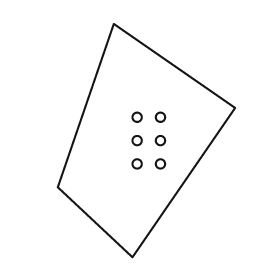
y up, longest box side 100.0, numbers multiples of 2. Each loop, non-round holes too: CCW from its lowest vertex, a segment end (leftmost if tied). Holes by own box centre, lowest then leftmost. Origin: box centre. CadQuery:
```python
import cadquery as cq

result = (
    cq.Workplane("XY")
    .moveTo(-6.0, -50.0)
    .lineTo(38.0, 14.0)
    .lineTo(-14.0, 50.0)
    .lineTo(-38.0, -20.0)
    .close()
    .moveTo(-4.0, -10.0)
    .circle(2.0)
    .moveTo(6.0, -10.0)
    .circle(2.0)
    .moveTo(-4.0, 0.0)
    .circle(2.0)
    .moveTo(6.0, 0.0)
    .circle(2.0)
    .moveTo(-4.0, 10.0)
    .circle(2.0)
    .moveTo(6.0, 10.0)
    .circle(2.0)
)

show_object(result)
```